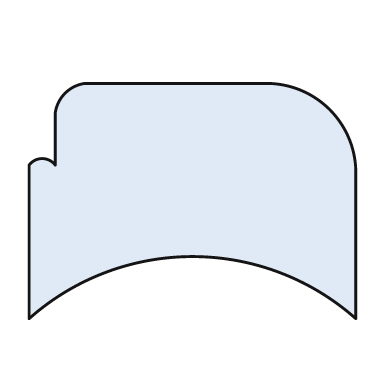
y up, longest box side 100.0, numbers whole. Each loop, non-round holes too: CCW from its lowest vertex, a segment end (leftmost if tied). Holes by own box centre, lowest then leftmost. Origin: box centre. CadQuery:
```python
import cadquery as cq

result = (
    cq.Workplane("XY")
    .moveTo(-50.0, -36.0)
    .threePointArc((0.0, -17.0), (50.0, -36.0))
    .lineTo(50.0, 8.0)
    .threePointArc((42.0, 28.0), (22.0, 36.0))
    .lineTo(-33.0, 36.0)
    .threePointArc((-39.0, 33.0), (-42.0, 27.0))
    .lineTo(-42.0, 11.0)
    .threePointArc((-46.0, 13.0), (-50.0, 11.0))
    .close()
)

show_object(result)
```